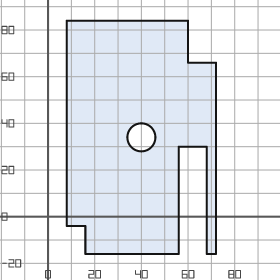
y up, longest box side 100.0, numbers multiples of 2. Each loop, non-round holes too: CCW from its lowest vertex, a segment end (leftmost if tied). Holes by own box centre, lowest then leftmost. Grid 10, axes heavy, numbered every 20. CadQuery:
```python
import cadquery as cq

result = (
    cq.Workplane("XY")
    .moveTo(16.0, -16.0)
    .lineTo(56.0, -16.0)
    .lineTo(56.0, 30.0)
    .lineTo(68.0, 30.0)
    .lineTo(68.0, -16.0)
    .lineTo(72.0, -16.0)
    .lineTo(72.0, 66.0)
    .lineTo(60.0, 66.0)
    .lineTo(60.0, 84.0)
    .lineTo(8.0, 84.0)
    .lineTo(8.0, -4.0)
    .lineTo(16.0, -4.0)
    .close()
    .moveTo(40.0, 34.0)
    .circle(6.0)
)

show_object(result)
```